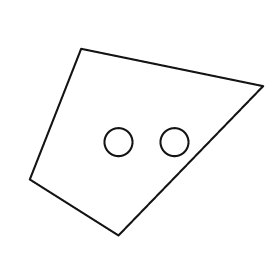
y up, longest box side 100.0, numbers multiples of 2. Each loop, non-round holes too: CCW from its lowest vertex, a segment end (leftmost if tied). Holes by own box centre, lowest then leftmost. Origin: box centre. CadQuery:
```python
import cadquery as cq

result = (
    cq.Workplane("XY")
    .moveTo(-12.0, -40.0)
    .lineTo(50.0, 24.0)
    .lineTo(-28.0, 40.0)
    .lineTo(-50.0, -16.0)
    .close()
    .moveTo(-12.0, 0.0)
    .circle(6.0)
    .moveTo(12.0, 0.0)
    .circle(6.0)
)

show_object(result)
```